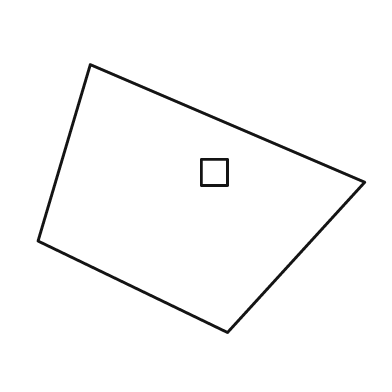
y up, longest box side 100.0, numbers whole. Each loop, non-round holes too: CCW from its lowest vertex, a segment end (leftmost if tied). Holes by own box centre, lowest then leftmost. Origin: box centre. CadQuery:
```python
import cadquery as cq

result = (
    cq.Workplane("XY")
    .moveTo(8.0, -41.0)
    .lineTo(50.0, 5.0)
    .lineTo(-34.0, 41.0)
    .lineTo(-50.0, -13.0)
    .close()
    .moveTo(0.0, 4.0)
    .lineTo(8.0, 4.0)
    .lineTo(8.0, 12.0)
    .lineTo(0.0, 12.0)
    .close()
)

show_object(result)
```